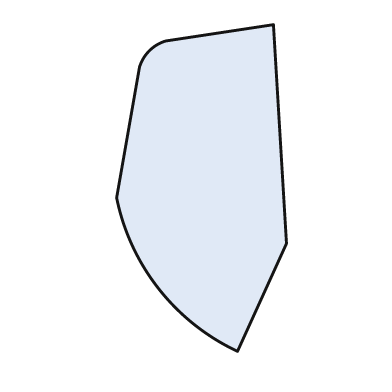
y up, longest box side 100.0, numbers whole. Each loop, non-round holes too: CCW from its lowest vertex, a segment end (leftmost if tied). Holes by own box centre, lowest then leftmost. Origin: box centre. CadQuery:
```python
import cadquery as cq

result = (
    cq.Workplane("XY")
    .moveTo(11.0, -50.0)
    .lineTo(26.0, -17.0)
    .lineTo(22.0, 50.0)
    .lineTo(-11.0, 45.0)
    .threePointArc((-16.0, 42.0), (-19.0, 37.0))
    .lineTo(-26.0, -3.0)
    .threePointArc((-13.0, -31.0), (11.0, -50.0))
    .close()
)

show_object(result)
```